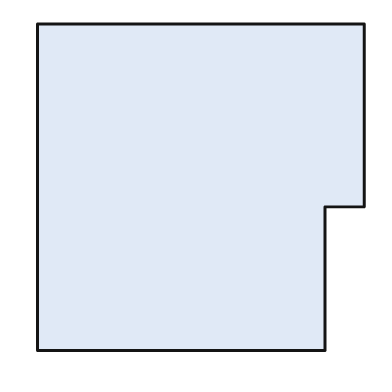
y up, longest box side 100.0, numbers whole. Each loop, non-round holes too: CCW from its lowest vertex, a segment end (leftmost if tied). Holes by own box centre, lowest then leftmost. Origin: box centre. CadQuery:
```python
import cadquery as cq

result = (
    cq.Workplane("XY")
    .moveTo(-50.0, -50.0)
    .lineTo(38.0, -50.0)
    .lineTo(38.0, -6.0)
    .lineTo(50.0, -6.0)
    .lineTo(50.0, 50.0)
    .lineTo(-50.0, 50.0)
    .close()
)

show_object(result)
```